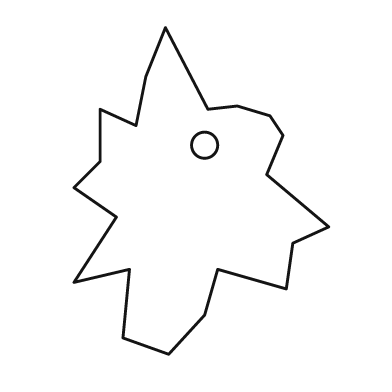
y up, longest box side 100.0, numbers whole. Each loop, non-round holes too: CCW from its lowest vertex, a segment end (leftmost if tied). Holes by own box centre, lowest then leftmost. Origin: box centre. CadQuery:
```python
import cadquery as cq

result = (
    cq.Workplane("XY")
    .moveTo(-10.0, -50.0)
    .lineTo(1.0, -38.0)
    .lineTo(5.0, -24.0)
    .lineTo(26.0, -30.0)
    .lineTo(28.0, -16.0)
    .lineTo(39.0, -11.0)
    .lineTo(20.0, 5.0)
    .lineTo(25.0, 17.0)
    .lineTo(21.0, 23.0)
    .lineTo(11.0, 26.0)
    .lineTo(2.0, 25.0)
    .lineTo(-11.0, 50.0)
    .lineTo(-17.0, 35.0)
    .lineTo(-20.0, 20.0)
    .lineTo(-31.0, 25.0)
    .lineTo(-31.0, 9.0)
    .lineTo(-39.0, 1.0)
    .lineTo(-26.0, -8.0)
    .lineTo(-39.0, -28.0)
    .lineTo(-22.0, -24.0)
    .lineTo(-24.0, -45.0)
    .close()
    .moveTo(1.0, 14.0)
    .circle(4.0)
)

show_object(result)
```